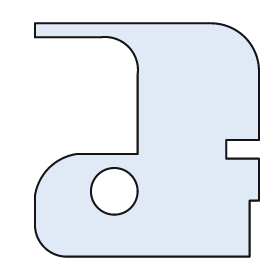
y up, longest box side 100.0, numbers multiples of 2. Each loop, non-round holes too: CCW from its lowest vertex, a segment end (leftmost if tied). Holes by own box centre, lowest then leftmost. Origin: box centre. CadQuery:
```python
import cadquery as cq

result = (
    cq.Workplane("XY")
    .moveTo(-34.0, -50.0)
    .lineTo(44.0, -50.0)
    .lineTo(44.0, -26.0)
    .lineTo(48.0, -26.0)
    .lineTo(48.0, -8.0)
    .lineTo(34.0, -8.0)
    .lineTo(34.0, 0.0)
    .lineTo(48.0, 0.0)
    .lineTo(48.0, 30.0)
    .threePointArc((42.0, 44.0), (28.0, 50.0))
    .lineTo(-48.0, 50.0)
    .lineTo(-48.0, 44.0)
    .lineTo(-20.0, 44.0)
    .threePointArc((-8.0, 40.0), (-4.0, 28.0))
    .lineTo(-4.0, -6.0)
    .lineTo(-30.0, -6.0)
    .threePointArc((-42.0, -12.0), (-48.0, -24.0))
    .lineTo(-48.0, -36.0)
    .threePointArc((-44.0, -46.0), (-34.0, -50.0))
    .close()
    .moveTo(-14.0, -22.0)
    .circle(10.0)
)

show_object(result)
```